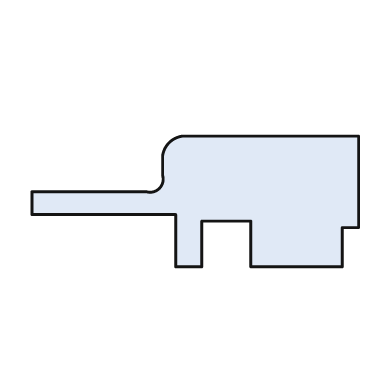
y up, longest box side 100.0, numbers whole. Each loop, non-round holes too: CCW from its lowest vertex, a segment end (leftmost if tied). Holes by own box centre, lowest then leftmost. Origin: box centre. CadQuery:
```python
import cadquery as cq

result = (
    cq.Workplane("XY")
    .moveTo(-6.0, -20.0)
    .lineTo(2.0, -20.0)
    .lineTo(2.0, -6.0)
    .lineTo(17.0, -6.0)
    .lineTo(17.0, -20.0)
    .lineTo(45.0, -20.0)
    .lineTo(45.0, -8.0)
    .lineTo(50.0, -8.0)
    .lineTo(50.0, 20.0)
    .lineTo(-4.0, 20.0)
    .threePointArc((-8.0, 18.0), (-10.0, 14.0))
    .lineTo(-10.0, 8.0)
    .threePointArc((-11.0, 4.0), (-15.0, 3.0))
    .lineTo(-50.0, 3.0)
    .lineTo(-50.0, -4.0)
    .lineTo(-6.0, -4.0)
    .close()
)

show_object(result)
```